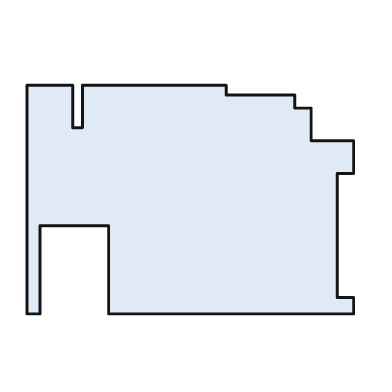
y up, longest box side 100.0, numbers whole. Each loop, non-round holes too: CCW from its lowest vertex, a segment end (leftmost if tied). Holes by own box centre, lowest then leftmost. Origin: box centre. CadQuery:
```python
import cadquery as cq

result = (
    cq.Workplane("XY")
    .moveTo(-50.0, -35.0)
    .lineTo(-46.0, -35.0)
    .lineTo(-46.0, -8.0)
    .lineTo(-25.0, -8.0)
    .lineTo(-25.0, -35.0)
    .lineTo(50.0, -35.0)
    .lineTo(50.0, -30.0)
    .lineTo(45.0, -30.0)
    .lineTo(45.0, 8.0)
    .lineTo(50.0, 8.0)
    .lineTo(50.0, 18.0)
    .lineTo(37.0, 18.0)
    .lineTo(37.0, 28.0)
    .lineTo(32.0, 28.0)
    .lineTo(32.0, 32.0)
    .lineTo(11.0, 32.0)
    .lineTo(11.0, 35.0)
    .lineTo(-33.0, 35.0)
    .lineTo(-33.0, 22.0)
    .lineTo(-36.0, 22.0)
    .lineTo(-36.0, 35.0)
    .lineTo(-50.0, 35.0)
    .close()
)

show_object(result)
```